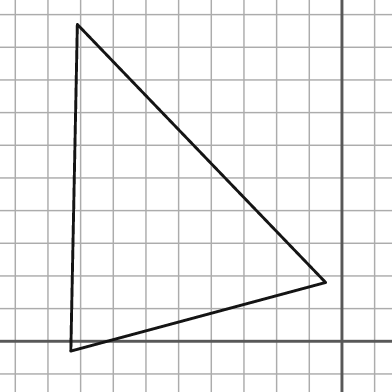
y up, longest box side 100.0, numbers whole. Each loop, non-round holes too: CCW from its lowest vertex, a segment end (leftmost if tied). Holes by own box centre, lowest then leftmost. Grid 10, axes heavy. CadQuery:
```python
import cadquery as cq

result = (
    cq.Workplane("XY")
    .moveTo(-83.0, -3.0)
    .lineTo(-5.0, 18.0)
    .lineTo(-81.0, 97.0)
    .close()
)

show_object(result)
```